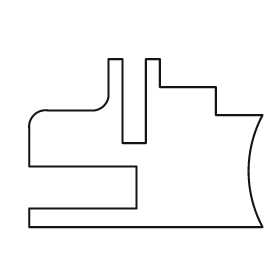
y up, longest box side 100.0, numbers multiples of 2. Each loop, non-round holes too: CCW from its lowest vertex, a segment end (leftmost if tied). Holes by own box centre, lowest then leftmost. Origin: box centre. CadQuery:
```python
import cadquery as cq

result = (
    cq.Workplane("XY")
    .moveTo(-50.0, -36.0)
    .lineTo(50.0, -36.0)
    .threePointArc((44.0, -12.0), (50.0, 12.0))
    .lineTo(30.0, 12.0)
    .lineTo(30.0, 24.0)
    .lineTo(6.0, 24.0)
    .lineTo(6.0, 36.0)
    .lineTo(0.0, 36.0)
    .lineTo(0.0, 0.0)
    .lineTo(-10.0, 0.0)
    .lineTo(-10.0, 36.0)
    .lineTo(-16.0, 36.0)
    .lineTo(-16.0, 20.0)
    .threePointArc((-18.0, 16.0), (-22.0, 14.0))
    .lineTo(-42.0, 14.0)
    .threePointArc((-48.0, 12.0), (-50.0, 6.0))
    .lineTo(-50.0, -10.0)
    .lineTo(-4.0, -10.0)
    .lineTo(-4.0, -28.0)
    .lineTo(-50.0, -28.0)
    .close()
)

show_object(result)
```